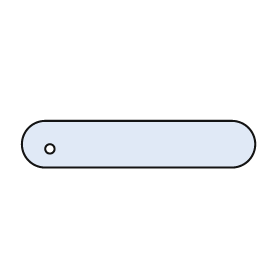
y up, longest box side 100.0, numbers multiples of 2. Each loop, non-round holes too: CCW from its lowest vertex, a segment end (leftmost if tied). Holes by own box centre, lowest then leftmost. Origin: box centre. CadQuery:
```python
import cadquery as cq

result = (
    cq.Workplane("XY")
    .moveTo(-40.0, -10.0)
    .lineTo(40.0, -10.0)
    .threePointArc((50.0, 0.0), (40.0, 10.0))
    .lineTo(-40.0, 10.0)
    .threePointArc((-50.0, 0.0), (-40.0, -10.0))
    .close()
    .moveTo(-38.0, -2.0)
    .circle(2.0)
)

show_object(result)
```